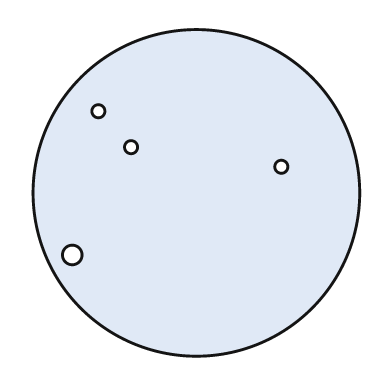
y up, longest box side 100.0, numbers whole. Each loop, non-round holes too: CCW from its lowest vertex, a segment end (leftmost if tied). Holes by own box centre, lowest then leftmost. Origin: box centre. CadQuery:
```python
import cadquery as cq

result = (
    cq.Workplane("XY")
    .moveTo(0.0, 0.0)
    .circle(50.0)
    .moveTo(-38.0, -19.0)
    .circle(3.0)
    .moveTo(26.0, 8.0)
    .circle(2.0)
    .moveTo(-20.0, 14.0)
    .circle(2.0)
    .moveTo(-30.0, 25.0)
    .circle(2.0)
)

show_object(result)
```